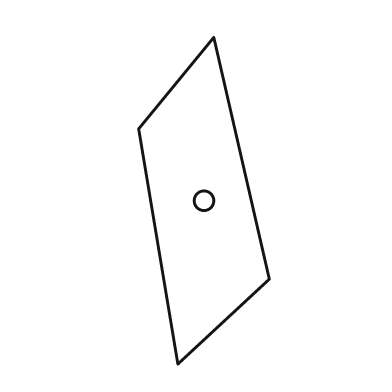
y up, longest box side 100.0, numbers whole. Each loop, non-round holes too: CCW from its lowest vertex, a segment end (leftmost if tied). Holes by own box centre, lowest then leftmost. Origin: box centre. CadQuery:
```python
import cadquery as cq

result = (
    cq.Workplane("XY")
    .moveTo(-8.0, -50.0)
    .lineTo(20.0, -24.0)
    .lineTo(3.0, 50.0)
    .lineTo(-20.0, 22.0)
    .close()
    .moveTo(0.0, 0.0)
    .circle(3.0)
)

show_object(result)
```